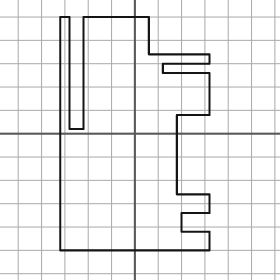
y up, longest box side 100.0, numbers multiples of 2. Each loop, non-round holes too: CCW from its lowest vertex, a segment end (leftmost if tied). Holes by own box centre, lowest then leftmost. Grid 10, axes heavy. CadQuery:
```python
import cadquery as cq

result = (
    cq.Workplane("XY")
    .moveTo(-32.0, -50.0)
    .lineTo(32.0, -50.0)
    .lineTo(32.0, -42.0)
    .lineTo(20.0, -42.0)
    .lineTo(20.0, -34.0)
    .lineTo(32.0, -34.0)
    .lineTo(32.0, -26.0)
    .lineTo(18.0, -26.0)
    .lineTo(18.0, 8.0)
    .lineTo(32.0, 8.0)
    .lineTo(32.0, 26.0)
    .lineTo(12.0, 26.0)
    .lineTo(12.0, 30.0)
    .lineTo(32.0, 30.0)
    .lineTo(32.0, 34.0)
    .lineTo(6.0, 34.0)
    .lineTo(6.0, 50.0)
    .lineTo(-22.0, 50.0)
    .lineTo(-22.0, 2.0)
    .lineTo(-28.0, 2.0)
    .lineTo(-28.0, 50.0)
    .lineTo(-32.0, 50.0)
    .close()
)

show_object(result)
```